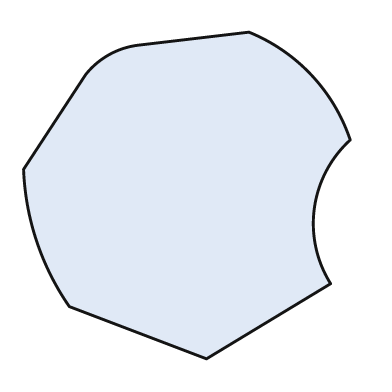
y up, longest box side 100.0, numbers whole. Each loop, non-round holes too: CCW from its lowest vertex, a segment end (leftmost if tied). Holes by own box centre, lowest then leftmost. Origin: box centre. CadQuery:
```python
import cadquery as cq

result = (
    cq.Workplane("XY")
    .moveTo(6.0, -50.0)
    .lineTo(44.0, -27.0)
    .threePointArc((39.0, -4.0), (50.0, 17.0))
    .threePointArc((38.0, 37.0), (19.0, 50.0))
    .lineTo(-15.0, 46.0)
    .threePointArc((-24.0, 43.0), (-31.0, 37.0))
    .lineTo(-50.0, 8.0)
    .threePointArc((-46.0, -14.0), (-36.0, -34.0))
    .close()
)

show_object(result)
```